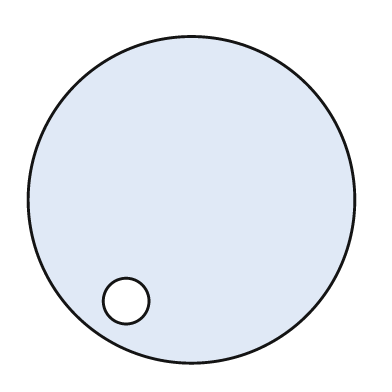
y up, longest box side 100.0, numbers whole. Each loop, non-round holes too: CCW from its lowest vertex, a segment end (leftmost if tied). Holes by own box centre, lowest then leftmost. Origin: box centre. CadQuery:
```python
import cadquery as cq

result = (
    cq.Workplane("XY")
    .moveTo(0.0, 0.0)
    .circle(50.0)
    .moveTo(-20.0, -31.0)
    .circle(7.0)
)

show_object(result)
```